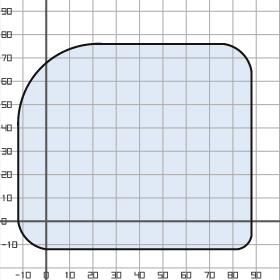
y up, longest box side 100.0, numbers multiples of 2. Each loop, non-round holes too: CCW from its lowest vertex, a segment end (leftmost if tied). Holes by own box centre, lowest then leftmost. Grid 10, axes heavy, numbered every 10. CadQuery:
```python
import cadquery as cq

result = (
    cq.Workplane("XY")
    .moveTo(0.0, -12.0)
    .lineTo(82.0, -12.0)
    .threePointArc((86.0, -10.0), (88.0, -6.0))
    .lineTo(88.0, 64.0)
    .threePointArc((84.0, 72.0), (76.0, 76.0))
    .lineTo(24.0, 76.0)
    .threePointArc((-2.0, 66.0), (-12.0, 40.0))
    .lineTo(-12.0, 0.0)
    .threePointArc((-8.0, -8.0), (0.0, -12.0))
    .close()
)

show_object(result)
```